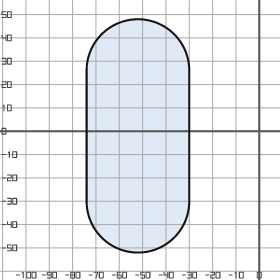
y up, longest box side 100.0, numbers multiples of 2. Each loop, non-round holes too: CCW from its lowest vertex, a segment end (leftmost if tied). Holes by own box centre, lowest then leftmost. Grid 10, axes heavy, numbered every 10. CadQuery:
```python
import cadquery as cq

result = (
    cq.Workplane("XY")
    .moveTo(-74.0, -30.0)
    .threePointArc((-52.0, -52.0), (-30.0, -30.0))
    .lineTo(-30.0, 26.0)
    .threePointArc((-52.0, 48.0), (-74.0, 26.0))
    .close()
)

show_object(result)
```